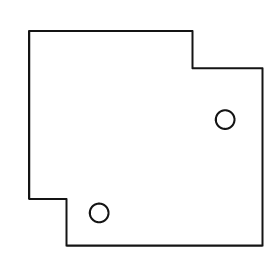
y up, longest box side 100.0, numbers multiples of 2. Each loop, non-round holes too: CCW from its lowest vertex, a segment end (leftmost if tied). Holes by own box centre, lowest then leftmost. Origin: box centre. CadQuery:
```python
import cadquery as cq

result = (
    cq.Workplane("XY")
    .moveTo(-34.0, -46.0)
    .lineTo(50.0, -46.0)
    .lineTo(50.0, 30.0)
    .lineTo(20.0, 30.0)
    .lineTo(20.0, 46.0)
    .lineTo(-50.0, 46.0)
    .lineTo(-50.0, -26.0)
    .lineTo(-34.0, -26.0)
    .close()
    .moveTo(-20.0, -32.0)
    .circle(4.0)
    .moveTo(34.0, 8.0)
    .circle(4.0)
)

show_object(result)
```